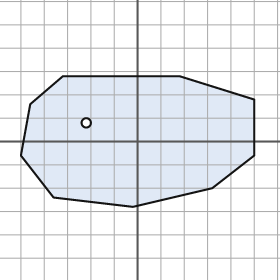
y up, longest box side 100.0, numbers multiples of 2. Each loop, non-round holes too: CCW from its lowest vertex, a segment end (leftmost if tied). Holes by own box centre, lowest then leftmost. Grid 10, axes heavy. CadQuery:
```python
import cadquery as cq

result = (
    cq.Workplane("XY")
    .moveTo(-2.0, -28.0)
    .lineTo(32.0, -20.0)
    .lineTo(50.0, -6.0)
    .lineTo(50.0, 18.0)
    .lineTo(18.0, 28.0)
    .lineTo(-32.0, 28.0)
    .lineTo(-46.0, 16.0)
    .lineTo(-50.0, -6.0)
    .lineTo(-36.0, -24.0)
    .close()
    .moveTo(-22.0, 8.0)
    .circle(2.0)
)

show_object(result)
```